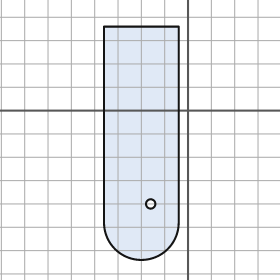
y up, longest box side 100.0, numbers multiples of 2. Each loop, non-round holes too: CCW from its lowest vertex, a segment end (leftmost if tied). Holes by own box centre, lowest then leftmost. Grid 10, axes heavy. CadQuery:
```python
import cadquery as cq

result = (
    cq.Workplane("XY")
    .moveTo(-36.0, -48.0)
    .threePointArc((-20.0, -64.0), (-4.0, -48.0))
    .lineTo(-4.0, 36.0)
    .lineTo(-36.0, 36.0)
    .close()
    .moveTo(-16.0, -40.0)
    .circle(2.0)
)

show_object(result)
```